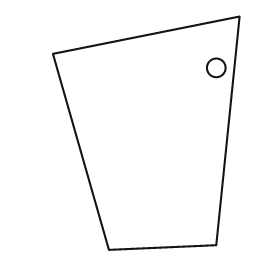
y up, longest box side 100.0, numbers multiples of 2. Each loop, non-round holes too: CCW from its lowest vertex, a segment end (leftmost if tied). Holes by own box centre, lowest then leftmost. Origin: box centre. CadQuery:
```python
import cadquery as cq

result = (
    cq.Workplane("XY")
    .moveTo(-16.0, -50.0)
    .lineTo(30.0, -48.0)
    .lineTo(40.0, 50.0)
    .lineTo(-40.0, 34.0)
    .close()
    .moveTo(30.0, 28.0)
    .circle(4.0)
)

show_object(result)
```